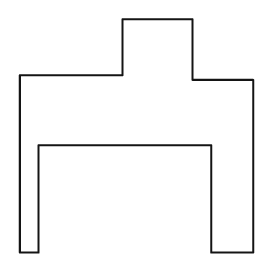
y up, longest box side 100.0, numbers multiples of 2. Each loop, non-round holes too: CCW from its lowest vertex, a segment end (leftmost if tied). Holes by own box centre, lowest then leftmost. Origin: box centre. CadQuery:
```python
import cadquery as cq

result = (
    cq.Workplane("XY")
    .moveTo(-50.0, -50.0)
    .lineTo(-42.0, -50.0)
    .lineTo(-42.0, -4.0)
    .lineTo(32.0, -4.0)
    .lineTo(32.0, -50.0)
    .lineTo(50.0, -50.0)
    .lineTo(50.0, 24.0)
    .lineTo(24.0, 24.0)
    .lineTo(24.0, 50.0)
    .lineTo(-6.0, 50.0)
    .lineTo(-6.0, 26.0)
    .lineTo(-50.0, 26.0)
    .close()
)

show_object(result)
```